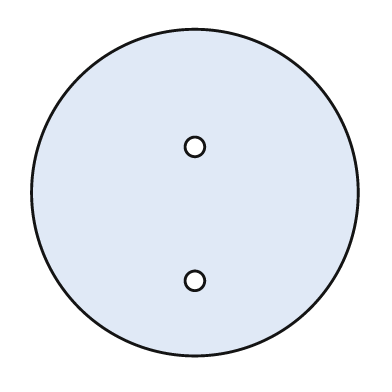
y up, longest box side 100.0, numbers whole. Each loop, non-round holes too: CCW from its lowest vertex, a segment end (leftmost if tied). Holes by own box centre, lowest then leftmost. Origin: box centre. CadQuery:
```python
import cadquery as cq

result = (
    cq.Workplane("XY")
    .moveTo(0.0, 0.0)
    .circle(50.0)
    .moveTo(0.0, -27.0)
    .circle(3.0)
    .moveTo(0.0, 14.0)
    .circle(3.0)
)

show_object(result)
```